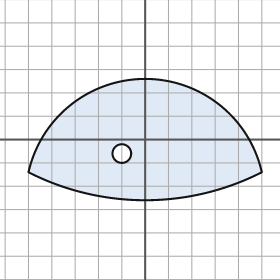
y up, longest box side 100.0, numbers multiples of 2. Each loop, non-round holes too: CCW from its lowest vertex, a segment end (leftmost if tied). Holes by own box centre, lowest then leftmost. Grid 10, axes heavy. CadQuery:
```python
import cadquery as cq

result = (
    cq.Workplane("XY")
    .moveTo(-50.0, -14.0)
    .threePointArc((0.0, -26.0), (50.0, -14.0))
    .threePointArc((0.0, 26.0), (-50.0, -14.0))
    .close()
    .moveTo(-10.0, -6.0)
    .circle(4.0)
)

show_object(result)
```